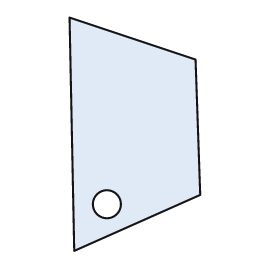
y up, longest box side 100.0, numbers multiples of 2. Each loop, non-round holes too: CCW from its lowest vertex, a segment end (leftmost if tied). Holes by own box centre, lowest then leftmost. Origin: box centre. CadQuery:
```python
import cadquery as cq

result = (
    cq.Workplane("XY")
    .moveTo(-26.0, -50.0)
    .lineTo(28.0, -26.0)
    .lineTo(26.0, 32.0)
    .lineTo(-28.0, 50.0)
    .close()
    .moveTo(-12.0, -30.0)
    .circle(6.0)
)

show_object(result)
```